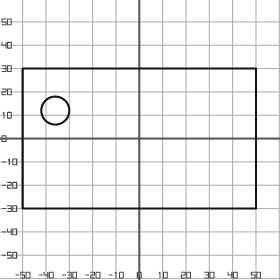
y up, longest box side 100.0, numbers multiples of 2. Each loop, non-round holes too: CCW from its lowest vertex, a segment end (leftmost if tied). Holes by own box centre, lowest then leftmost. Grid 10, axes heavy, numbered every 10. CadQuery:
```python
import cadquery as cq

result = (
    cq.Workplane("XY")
    .moveTo(-50.0, -30.0)
    .lineTo(50.0, -30.0)
    .lineTo(50.0, 30.0)
    .lineTo(-50.0, 30.0)
    .close()
    .moveTo(-36.0, 12.0)
    .circle(6.0)
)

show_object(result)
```